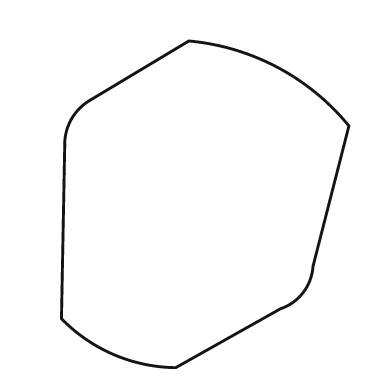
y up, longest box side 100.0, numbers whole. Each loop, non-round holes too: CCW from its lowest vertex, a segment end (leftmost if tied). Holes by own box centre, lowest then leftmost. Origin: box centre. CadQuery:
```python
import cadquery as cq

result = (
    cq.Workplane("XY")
    .moveTo(-9.0, -50.0)
    .lineTo(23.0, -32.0)
    .threePointArc((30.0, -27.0), (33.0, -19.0))
    .lineTo(44.0, 24.0)
    .threePointArc((22.0, 42.0), (-5.0, 50.0))
    .lineTo(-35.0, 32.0)
    .threePointArc((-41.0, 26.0), (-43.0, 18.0))
    .lineTo(-44.0, -35.0)
    .threePointArc((-28.0, -46.0), (-9.0, -50.0))
    .close()
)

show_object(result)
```